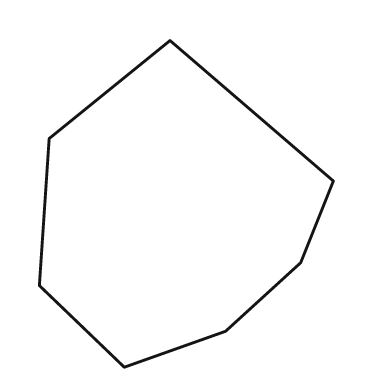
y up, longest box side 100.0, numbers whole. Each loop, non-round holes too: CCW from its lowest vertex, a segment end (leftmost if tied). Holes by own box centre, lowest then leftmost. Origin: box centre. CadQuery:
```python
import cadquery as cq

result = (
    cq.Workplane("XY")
    .moveTo(-19.0, -50.0)
    .lineTo(12.0, -39.0)
    .lineTo(35.0, -18.0)
    .lineTo(45.0, 7.0)
    .lineTo(-5.0, 50.0)
    .lineTo(-42.0, 20.0)
    .lineTo(-45.0, -25.0)
    .close()
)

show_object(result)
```